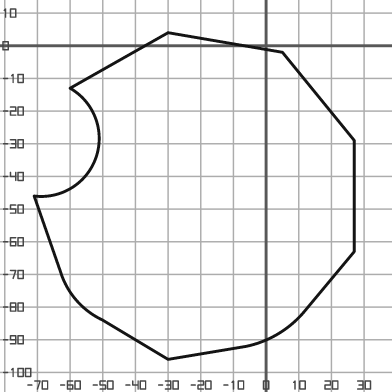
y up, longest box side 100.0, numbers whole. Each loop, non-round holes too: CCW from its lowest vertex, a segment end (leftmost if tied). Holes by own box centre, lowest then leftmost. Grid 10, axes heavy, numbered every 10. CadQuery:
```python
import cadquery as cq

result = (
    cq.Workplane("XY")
    .moveTo(-30.0, -96.0)
    .lineTo(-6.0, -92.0)
    .threePointArc((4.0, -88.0), (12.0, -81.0))
    .lineTo(27.0, -63.0)
    .lineTo(27.0, -29.0)
    .lineTo(5.0, -2.0)
    .lineTo(-30.0, 4.0)
    .lineTo(-60.0, -13.0)
    .threePointArc((-52.0, -34.0), (-71.0, -46.0))
    .lineTo(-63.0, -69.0)
    .threePointArc((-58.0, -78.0), (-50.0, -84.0))
    .close()
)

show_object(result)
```